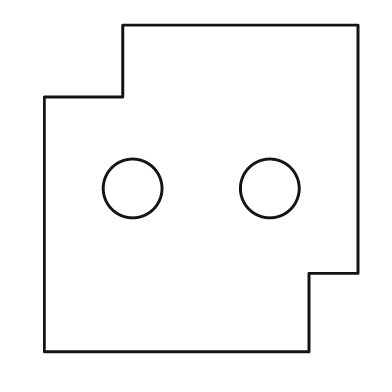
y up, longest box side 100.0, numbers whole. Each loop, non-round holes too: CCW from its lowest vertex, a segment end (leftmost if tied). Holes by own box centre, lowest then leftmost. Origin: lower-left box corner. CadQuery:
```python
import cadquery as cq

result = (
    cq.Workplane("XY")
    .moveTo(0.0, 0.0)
    .lineTo(81.0, 0.0)
    .lineTo(81.0, 24.0)
    .lineTo(96.0, 24.0)
    .lineTo(96.0, 100.0)
    .lineTo(24.0, 100.0)
    .lineTo(24.0, 78.0)
    .lineTo(0.0, 78.0)
    .close()
    .moveTo(27.0, 50.0)
    .circle(9.0)
    .moveTo(69.0, 50.0)
    .circle(9.0)
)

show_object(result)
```